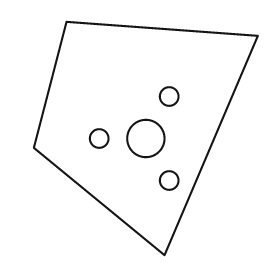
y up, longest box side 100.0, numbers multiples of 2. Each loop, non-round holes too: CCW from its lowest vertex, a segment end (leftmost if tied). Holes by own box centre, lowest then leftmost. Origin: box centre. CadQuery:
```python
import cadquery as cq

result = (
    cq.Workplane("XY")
    .moveTo(8.0, -50.0)
    .lineTo(48.0, 44.0)
    .lineTo(-34.0, 50.0)
    .lineTo(-48.0, -4.0)
    .close()
    .moveTo(10.0, -18.0)
    .circle(4.0)
    .moveTo(-20.0, 0.0)
    .circle(4.0)
    .moveTo(0.0, 0.0)
    .circle(8.0)
    .moveTo(10.0, 18.0)
    .circle(4.0)
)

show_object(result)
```